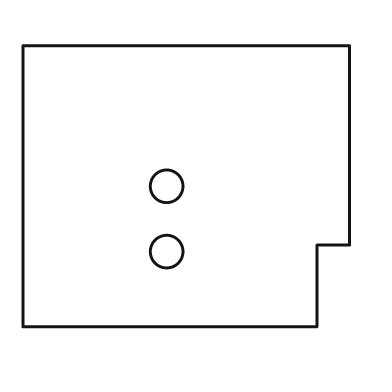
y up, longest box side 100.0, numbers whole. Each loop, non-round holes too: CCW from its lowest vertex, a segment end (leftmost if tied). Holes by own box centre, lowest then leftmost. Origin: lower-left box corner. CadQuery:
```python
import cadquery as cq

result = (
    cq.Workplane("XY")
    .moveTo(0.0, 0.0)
    .lineTo(90.0, 0.0)
    .lineTo(90.0, 25.0)
    .lineTo(100.0, 25.0)
    .lineTo(100.0, 86.0)
    .lineTo(0.0, 86.0)
    .close()
    .moveTo(44.0, 23.0)
    .circle(5.0)
    .moveTo(44.0, 43.0)
    .circle(5.0)
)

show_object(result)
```